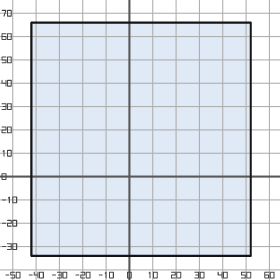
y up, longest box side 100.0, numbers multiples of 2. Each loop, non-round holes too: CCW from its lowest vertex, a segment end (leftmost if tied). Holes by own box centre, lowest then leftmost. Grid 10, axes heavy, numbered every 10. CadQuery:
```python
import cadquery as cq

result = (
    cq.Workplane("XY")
    .moveTo(-42.0, -34.0)
    .lineTo(52.0, -34.0)
    .lineTo(52.0, 66.0)
    .lineTo(-42.0, 66.0)
    .close()
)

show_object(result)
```